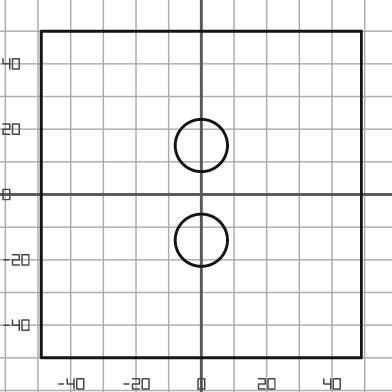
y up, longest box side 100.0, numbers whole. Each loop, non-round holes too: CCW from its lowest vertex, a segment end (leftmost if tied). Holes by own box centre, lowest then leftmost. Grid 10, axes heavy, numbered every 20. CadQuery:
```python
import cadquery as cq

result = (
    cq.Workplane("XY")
    .moveTo(-49.0, -50.0)
    .lineTo(49.0, -50.0)
    .lineTo(49.0, 50.0)
    .lineTo(-49.0, 50.0)
    .close()
    .moveTo(0.0, -14.0)
    .circle(8.0)
    .moveTo(0.0, 15.0)
    .circle(8.0)
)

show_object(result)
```